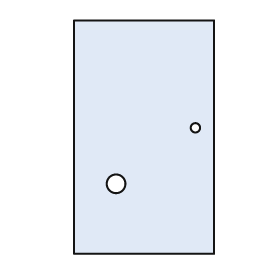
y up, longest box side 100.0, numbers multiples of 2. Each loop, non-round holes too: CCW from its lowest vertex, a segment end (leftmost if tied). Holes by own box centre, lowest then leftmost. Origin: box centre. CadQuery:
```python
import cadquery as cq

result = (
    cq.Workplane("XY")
    .moveTo(-30.0, -50.0)
    .lineTo(30.0, -50.0)
    .lineTo(30.0, 50.0)
    .lineTo(-30.0, 50.0)
    .close()
    .moveTo(-12.0, -20.0)
    .circle(4.0)
    .moveTo(22.0, 4.0)
    .circle(2.0)
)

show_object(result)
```